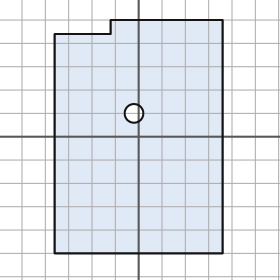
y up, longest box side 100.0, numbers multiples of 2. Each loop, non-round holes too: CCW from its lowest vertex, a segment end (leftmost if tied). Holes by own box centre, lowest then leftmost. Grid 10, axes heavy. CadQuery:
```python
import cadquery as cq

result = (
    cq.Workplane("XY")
    .moveTo(-36.0, -50.0)
    .lineTo(36.0, -50.0)
    .lineTo(36.0, 50.0)
    .lineTo(-12.0, 50.0)
    .lineTo(-12.0, 44.0)
    .lineTo(-36.0, 44.0)
    .close()
    .moveTo(-2.0, 10.0)
    .circle(4.0)
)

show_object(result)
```